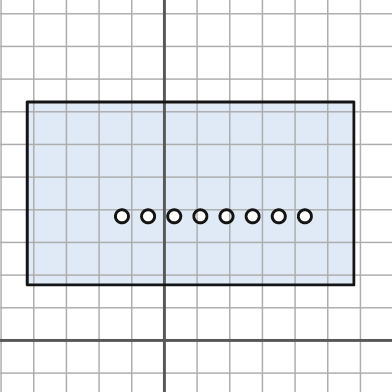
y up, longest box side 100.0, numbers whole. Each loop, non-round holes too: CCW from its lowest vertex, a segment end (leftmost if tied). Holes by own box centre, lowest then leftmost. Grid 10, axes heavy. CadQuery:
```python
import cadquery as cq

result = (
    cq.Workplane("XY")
    .moveTo(-42.0, 17.0)
    .lineTo(58.0, 17.0)
    .lineTo(58.0, 73.0)
    .lineTo(-42.0, 73.0)
    .close()
    .moveTo(-13.0, 38.0)
    .circle(2.0)
    .moveTo(-5.0, 38.0)
    .circle(2.0)
    .moveTo(3.0, 38.0)
    .circle(2.0)
    .moveTo(11.0, 38.0)
    .circle(2.0)
    .moveTo(19.0, 38.0)
    .circle(2.0)
    .moveTo(27.0, 38.0)
    .circle(2.0)
    .moveTo(35.0, 38.0)
    .circle(2.0)
    .moveTo(43.0, 38.0)
    .circle(2.0)
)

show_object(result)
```